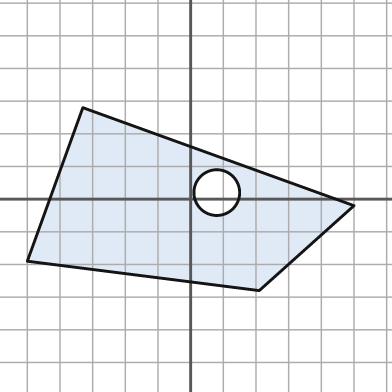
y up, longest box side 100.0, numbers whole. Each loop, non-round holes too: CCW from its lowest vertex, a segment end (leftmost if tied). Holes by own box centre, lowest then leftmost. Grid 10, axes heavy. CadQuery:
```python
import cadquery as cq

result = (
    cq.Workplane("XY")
    .moveTo(21.0, -28.0)
    .lineTo(50.0, -2.0)
    .lineTo(-33.0, 28.0)
    .lineTo(-50.0, -19.0)
    .close()
    .moveTo(8.0, 2.0)
    .circle(7.0)
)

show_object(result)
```